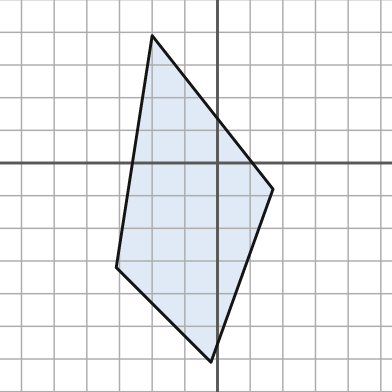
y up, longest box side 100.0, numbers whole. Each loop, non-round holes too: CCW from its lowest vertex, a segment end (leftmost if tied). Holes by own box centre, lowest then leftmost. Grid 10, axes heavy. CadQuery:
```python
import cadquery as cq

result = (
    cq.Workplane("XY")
    .moveTo(-2.0, -61.0)
    .lineTo(17.0, -8.0)
    .lineTo(-20.0, 39.0)
    .lineTo(-31.0, -32.0)
    .close()
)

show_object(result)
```